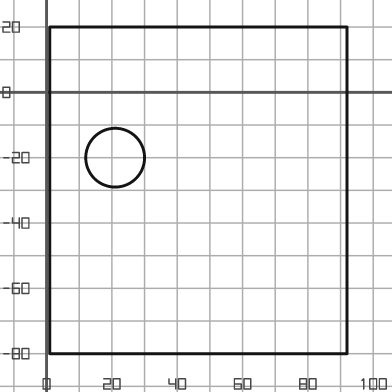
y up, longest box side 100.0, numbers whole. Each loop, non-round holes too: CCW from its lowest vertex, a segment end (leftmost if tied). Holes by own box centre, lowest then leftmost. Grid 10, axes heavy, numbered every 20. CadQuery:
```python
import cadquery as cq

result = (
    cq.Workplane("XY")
    .moveTo(1.0, -80.0)
    .lineTo(92.0, -80.0)
    .lineTo(92.0, 20.0)
    .lineTo(1.0, 20.0)
    .close()
    .moveTo(21.0, -20.0)
    .circle(9.0)
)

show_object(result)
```